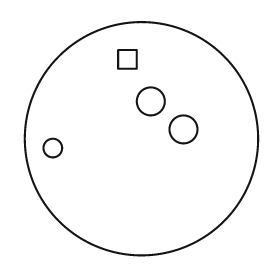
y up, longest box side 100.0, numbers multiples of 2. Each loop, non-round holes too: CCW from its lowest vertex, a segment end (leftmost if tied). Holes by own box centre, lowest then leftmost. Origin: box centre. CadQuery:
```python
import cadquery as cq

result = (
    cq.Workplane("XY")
    .moveTo(0.0, 0.0)
    .circle(50.0)
    .moveTo(-38.0, -4.0)
    .circle(4.0)
    .moveTo(18.0, 4.0)
    .circle(6.0)
    .moveTo(4.0, 16.0)
    .circle(6.0)
    .moveTo(-10.0, 30.0)
    .lineTo(-2.0, 30.0)
    .lineTo(-2.0, 38.0)
    .lineTo(-10.0, 38.0)
    .close()
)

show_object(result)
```